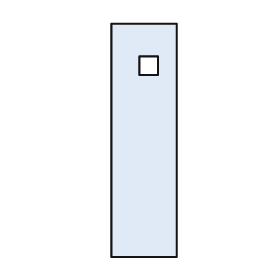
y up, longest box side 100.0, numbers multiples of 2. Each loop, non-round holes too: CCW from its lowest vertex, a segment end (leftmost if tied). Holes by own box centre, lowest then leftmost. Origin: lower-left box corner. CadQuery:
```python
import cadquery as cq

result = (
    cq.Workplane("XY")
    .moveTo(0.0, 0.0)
    .lineTo(28.0, 0.0)
    .lineTo(28.0, 100.0)
    .lineTo(0.0, 100.0)
    .close()
    .moveTo(12.0, 78.0)
    .lineTo(20.0, 78.0)
    .lineTo(20.0, 86.0)
    .lineTo(12.0, 86.0)
    .close()
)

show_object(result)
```